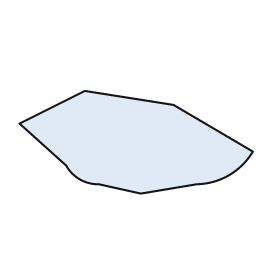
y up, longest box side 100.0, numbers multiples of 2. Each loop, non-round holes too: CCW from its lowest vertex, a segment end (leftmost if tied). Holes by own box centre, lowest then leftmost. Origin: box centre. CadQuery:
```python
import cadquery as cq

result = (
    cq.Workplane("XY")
    .moveTo(2.0, -22.0)
    .lineTo(26.0, -18.0)
    .threePointArc((40.0, -14.0), (50.0, -4.0))
    .lineTo(16.0, 16.0)
    .lineTo(-22.0, 22.0)
    .lineTo(-50.0, 8.0)
    .lineTo(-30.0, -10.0)
    .threePointArc((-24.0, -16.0), (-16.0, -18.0))
    .close()
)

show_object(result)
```